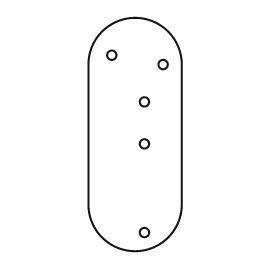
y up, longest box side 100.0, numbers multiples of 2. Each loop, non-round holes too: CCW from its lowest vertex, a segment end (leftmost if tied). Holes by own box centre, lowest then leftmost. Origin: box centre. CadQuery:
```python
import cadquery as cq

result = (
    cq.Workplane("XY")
    .moveTo(-20.0, -30.0)
    .threePointArc((0.0, -50.0), (20.0, -30.0))
    .lineTo(20.0, 30.0)
    .threePointArc((0.0, 50.0), (-20.0, 30.0))
    .close()
    .moveTo(4.0, -42.0)
    .circle(2.0)
    .moveTo(4.0, -4.0)
    .circle(2.0)
    .moveTo(4.0, 14.0)
    .circle(2.0)
    .moveTo(12.0, 30.0)
    .circle(2.0)
    .moveTo(-10.0, 34.0)
    .circle(2.0)
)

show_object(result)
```